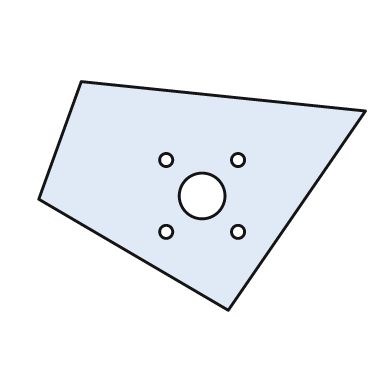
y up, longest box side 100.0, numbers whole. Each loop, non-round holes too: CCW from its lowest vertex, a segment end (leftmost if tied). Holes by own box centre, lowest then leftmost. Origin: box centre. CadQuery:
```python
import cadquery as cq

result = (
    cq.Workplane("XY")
    .moveTo(8.0, -35.0)
    .lineTo(50.0, 26.0)
    .lineTo(-37.0, 35.0)
    .lineTo(-50.0, -1.0)
    .close()
    .moveTo(-11.0, -11.0)
    .circle(2.0)
    .moveTo(11.0, -11.0)
    .circle(2.0)
    .moveTo(0.0, 0.0)
    .circle(7.0)
    .moveTo(-11.0, 11.0)
    .circle(2.0)
    .moveTo(11.0, 11.0)
    .circle(2.0)
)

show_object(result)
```